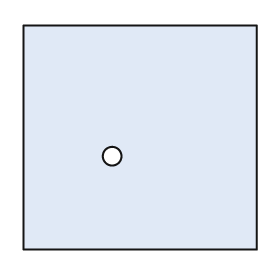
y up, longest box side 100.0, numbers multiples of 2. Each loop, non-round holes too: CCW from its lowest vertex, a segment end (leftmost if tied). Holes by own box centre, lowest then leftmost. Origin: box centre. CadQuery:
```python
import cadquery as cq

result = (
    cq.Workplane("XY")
    .moveTo(-50.0, -48.0)
    .lineTo(50.0, -48.0)
    .lineTo(50.0, 48.0)
    .lineTo(-50.0, 48.0)
    .close()
    .moveTo(-12.0, -8.0)
    .circle(4.0)
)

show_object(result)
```